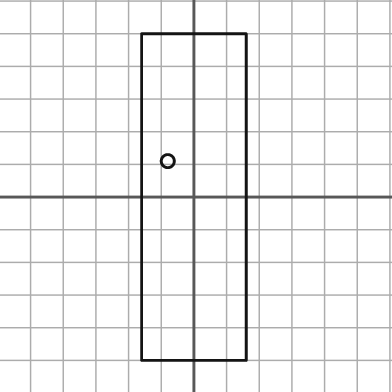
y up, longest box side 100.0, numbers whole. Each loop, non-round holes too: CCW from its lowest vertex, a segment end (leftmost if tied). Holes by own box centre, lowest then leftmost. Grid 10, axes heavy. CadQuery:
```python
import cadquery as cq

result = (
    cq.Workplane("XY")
    .moveTo(-16.0, -50.0)
    .lineTo(16.0, -50.0)
    .lineTo(16.0, 50.0)
    .lineTo(-16.0, 50.0)
    .close()
    .moveTo(-8.0, 11.0)
    .circle(2.0)
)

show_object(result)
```